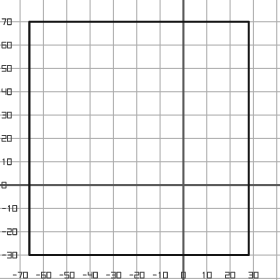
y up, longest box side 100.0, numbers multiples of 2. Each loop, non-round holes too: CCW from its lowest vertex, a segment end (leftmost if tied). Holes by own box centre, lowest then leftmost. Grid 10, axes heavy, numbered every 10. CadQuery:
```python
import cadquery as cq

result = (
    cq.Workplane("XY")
    .moveTo(-66.0, -30.0)
    .lineTo(28.0, -30.0)
    .lineTo(28.0, 70.0)
    .lineTo(-66.0, 70.0)
    .close()
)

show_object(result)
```